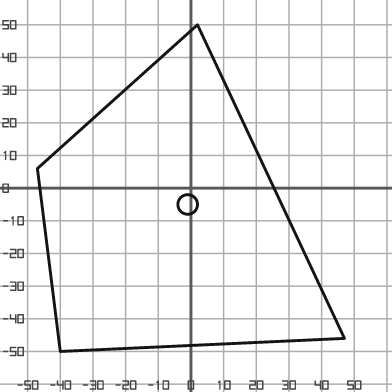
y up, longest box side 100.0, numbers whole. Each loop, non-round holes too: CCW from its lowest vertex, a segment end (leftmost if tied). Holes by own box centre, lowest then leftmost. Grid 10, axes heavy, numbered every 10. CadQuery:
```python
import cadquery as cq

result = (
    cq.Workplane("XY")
    .moveTo(-40.0, -50.0)
    .lineTo(47.0, -46.0)
    .lineTo(2.0, 50.0)
    .lineTo(-47.0, 6.0)
    .close()
    .moveTo(-1.0, -5.0)
    .circle(3.0)
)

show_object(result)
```